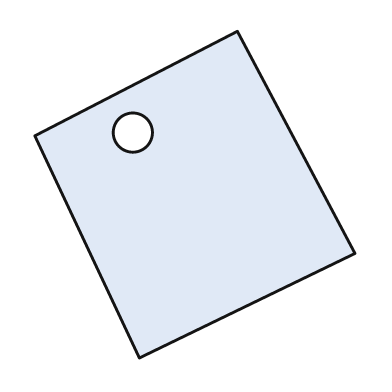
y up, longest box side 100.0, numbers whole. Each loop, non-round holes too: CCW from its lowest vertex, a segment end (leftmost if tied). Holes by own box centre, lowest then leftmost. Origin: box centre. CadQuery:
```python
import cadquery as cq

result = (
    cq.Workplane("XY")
    .moveTo(-17.0, -50.0)
    .lineTo(49.0, -18.0)
    .lineTo(13.0, 50.0)
    .lineTo(-49.0, 18.0)
    .close()
    .moveTo(-19.0, 19.0)
    .circle(6.0)
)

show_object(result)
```